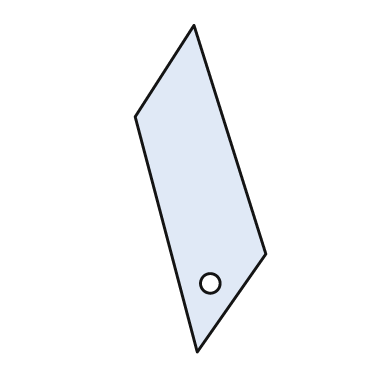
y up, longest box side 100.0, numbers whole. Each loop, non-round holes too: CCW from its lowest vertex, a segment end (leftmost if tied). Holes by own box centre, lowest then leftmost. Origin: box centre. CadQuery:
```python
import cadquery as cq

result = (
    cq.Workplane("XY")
    .moveTo(-1.0, -50.0)
    .lineTo(20.0, -20.0)
    .lineTo(-2.0, 50.0)
    .lineTo(-20.0, 22.0)
    .close()
    .moveTo(3.0, -29.0)
    .circle(3.0)
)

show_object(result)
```